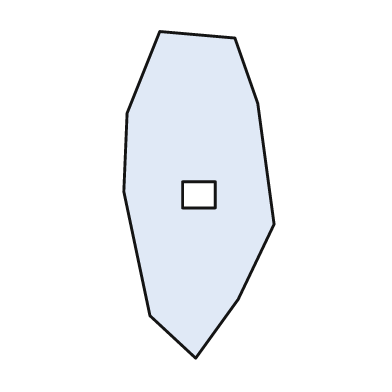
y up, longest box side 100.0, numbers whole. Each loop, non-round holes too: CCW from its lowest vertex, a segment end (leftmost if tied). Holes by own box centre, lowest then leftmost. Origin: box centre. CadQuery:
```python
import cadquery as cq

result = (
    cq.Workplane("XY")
    .moveTo(-1.0, -50.0)
    .lineTo(12.0, -32.0)
    .lineTo(23.0, -9.0)
    .lineTo(18.0, 28.0)
    .lineTo(11.0, 48.0)
    .lineTo(-12.0, 50.0)
    .lineTo(-22.0, 25.0)
    .lineTo(-23.0, 1.0)
    .lineTo(-15.0, -37.0)
    .close()
    .moveTo(-5.0, -4.0)
    .lineTo(5.0, -4.0)
    .lineTo(5.0, 4.0)
    .lineTo(-5.0, 4.0)
    .close()
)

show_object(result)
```